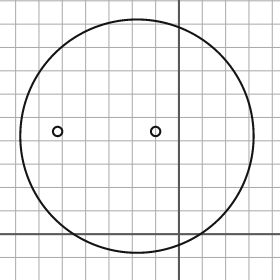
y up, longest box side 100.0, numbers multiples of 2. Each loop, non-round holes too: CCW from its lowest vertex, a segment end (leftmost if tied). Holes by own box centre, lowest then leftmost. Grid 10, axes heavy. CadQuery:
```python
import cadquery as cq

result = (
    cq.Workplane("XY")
    .moveTo(-18.0, 42.0)
    .circle(50.0)
    .moveTo(-52.0, 44.0)
    .circle(2.0)
    .moveTo(-10.0, 44.0)
    .circle(2.0)
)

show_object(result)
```